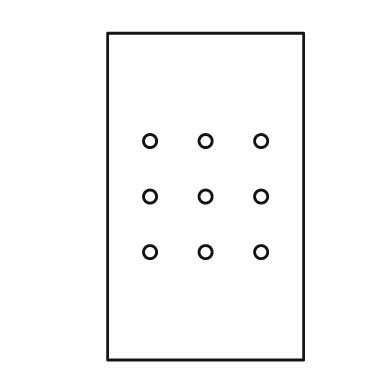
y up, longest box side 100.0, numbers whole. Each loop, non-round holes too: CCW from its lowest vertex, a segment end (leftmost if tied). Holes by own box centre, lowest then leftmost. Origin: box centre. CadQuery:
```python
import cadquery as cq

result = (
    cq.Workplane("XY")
    .moveTo(-30.0, -50.0)
    .lineTo(30.0, -50.0)
    .lineTo(30.0, 50.0)
    .lineTo(-30.0, 50.0)
    .close()
    .moveTo(-17.0, -17.0)
    .circle(2.0)
    .moveTo(0.0, -17.0)
    .circle(2.0)
    .moveTo(17.0, -17.0)
    .circle(2.0)
    .moveTo(-17.0, 0.0)
    .circle(2.0)
    .moveTo(0.0, 0.0)
    .circle(2.0)
    .moveTo(17.0, 0.0)
    .circle(2.0)
    .moveTo(-17.0, 17.0)
    .circle(2.0)
    .moveTo(0.0, 17.0)
    .circle(2.0)
    .moveTo(17.0, 17.0)
    .circle(2.0)
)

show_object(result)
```